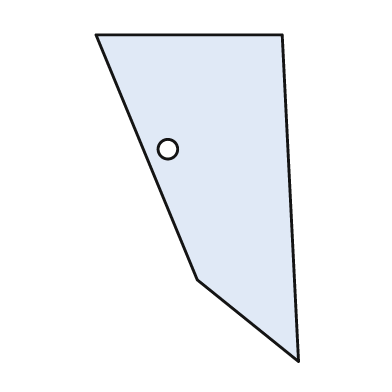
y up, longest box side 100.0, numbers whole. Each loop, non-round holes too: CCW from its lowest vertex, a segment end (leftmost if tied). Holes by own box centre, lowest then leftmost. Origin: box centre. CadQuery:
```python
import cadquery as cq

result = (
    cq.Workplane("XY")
    .moveTo(31.0, -50.0)
    .lineTo(26.0, 50.0)
    .lineTo(-31.0, 50.0)
    .lineTo(0.0, -25.0)
    .close()
    .moveTo(-9.0, 15.0)
    .circle(3.0)
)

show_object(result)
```